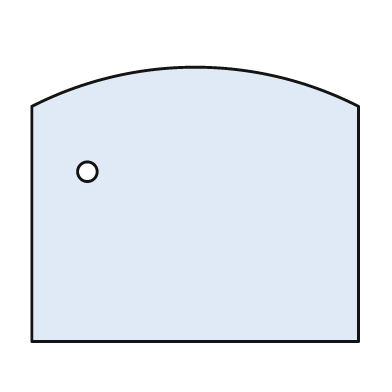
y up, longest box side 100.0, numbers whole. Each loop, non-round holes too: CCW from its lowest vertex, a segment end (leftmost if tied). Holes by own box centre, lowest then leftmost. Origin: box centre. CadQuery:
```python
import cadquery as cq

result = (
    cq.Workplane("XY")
    .moveTo(-50.0, -42.0)
    .lineTo(50.0, -42.0)
    .lineTo(50.0, 30.0)
    .threePointArc((0.0, 42.0), (-50.0, 30.0))
    .close()
    .moveTo(-33.0, 10.0)
    .circle(3.0)
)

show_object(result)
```